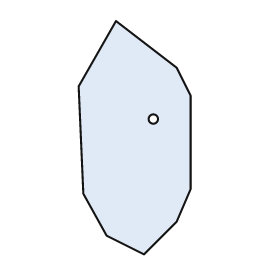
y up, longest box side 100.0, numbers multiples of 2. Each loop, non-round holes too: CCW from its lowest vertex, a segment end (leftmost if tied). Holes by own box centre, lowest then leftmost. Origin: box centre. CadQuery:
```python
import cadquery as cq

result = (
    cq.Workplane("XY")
    .moveTo(4.0, -50.0)
    .lineTo(18.0, -36.0)
    .lineTo(24.0, -22.0)
    .lineTo(24.0, 18.0)
    .lineTo(18.0, 30.0)
    .lineTo(-8.0, 50.0)
    .lineTo(-24.0, 22.0)
    .lineTo(-22.0, -24.0)
    .lineTo(-12.0, -42.0)
    .close()
    .moveTo(8.0, 8.0)
    .circle(2.0)
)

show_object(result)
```